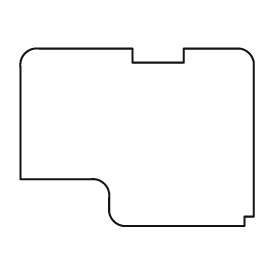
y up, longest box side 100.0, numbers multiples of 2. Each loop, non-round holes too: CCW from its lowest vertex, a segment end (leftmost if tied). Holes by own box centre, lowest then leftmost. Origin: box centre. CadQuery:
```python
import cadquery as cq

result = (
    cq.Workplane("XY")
    .moveTo(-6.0, -38.0)
    .lineTo(46.0, -38.0)
    .lineTo(46.0, -34.0)
    .lineTo(50.0, -34.0)
    .lineTo(50.0, 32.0)
    .threePointArc((48.0, 36.0), (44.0, 38.0))
    .lineTo(20.0, 38.0)
    .lineTo(20.0, 32.0)
    .lineTo(-2.0, 32.0)
    .lineTo(-2.0, 38.0)
    .lineTo(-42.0, 38.0)
    .threePointArc((-48.0, 36.0), (-50.0, 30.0))
    .lineTo(-50.0, -18.0)
    .lineTo(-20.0, -18.0)
    .threePointArc((-14.0, -20.0), (-12.0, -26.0))
    .lineTo(-12.0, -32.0)
    .threePointArc((-10.0, -36.0), (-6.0, -38.0))
    .close()
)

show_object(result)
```